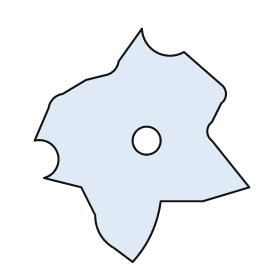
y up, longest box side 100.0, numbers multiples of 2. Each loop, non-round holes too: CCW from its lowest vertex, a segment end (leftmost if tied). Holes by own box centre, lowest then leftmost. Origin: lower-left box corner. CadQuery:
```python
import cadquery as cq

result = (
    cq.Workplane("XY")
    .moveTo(42.0, 0.0)
    .threePointArc((50.0, 12.0), (54.0, 26.0))
    .lineTo(72.0, 26.0)
    .lineTo(92.0, 32.0)
    .lineTo(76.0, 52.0)
    .threePointArc((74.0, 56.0), (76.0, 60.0))
    .lineTo(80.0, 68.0)
    .threePointArc((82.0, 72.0), (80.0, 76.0))
    .lineTo(64.0, 90.0)
    .threePointArc((52.0, 90.0), (46.0, 100.0))
    .lineTo(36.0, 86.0)
    .threePointArc((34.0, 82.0), (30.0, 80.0))
    .lineTo(22.0, 78.0)
    .lineTo(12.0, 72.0)
    .threePointArc((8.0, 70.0), (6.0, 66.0))
    .lineTo(0.0, 52.0)
    .threePointArc((10.0, 46.0), (4.0, 36.0))
    .lineTo(20.0, 32.0)
    .lineTo(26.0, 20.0)
    .threePointArc((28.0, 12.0), (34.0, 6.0))
    .close()
    .moveTo(48.0, 52.0)
    .circle(6.0)
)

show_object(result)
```